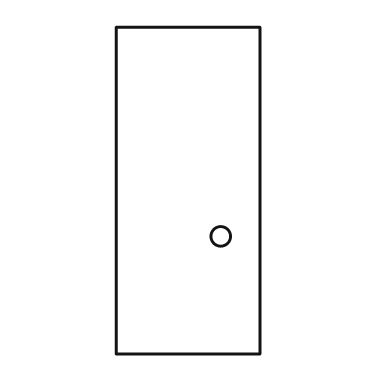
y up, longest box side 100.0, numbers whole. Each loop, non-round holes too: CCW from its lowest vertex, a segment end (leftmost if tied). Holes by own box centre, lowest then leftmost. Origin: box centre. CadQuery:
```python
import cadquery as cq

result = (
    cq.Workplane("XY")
    .moveTo(-22.0, -50.0)
    .lineTo(22.0, -50.0)
    .lineTo(22.0, 50.0)
    .lineTo(-22.0, 50.0)
    .close()
    .moveTo(10.0, -14.0)
    .circle(3.0)
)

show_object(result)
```